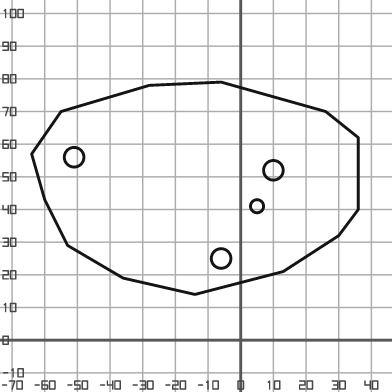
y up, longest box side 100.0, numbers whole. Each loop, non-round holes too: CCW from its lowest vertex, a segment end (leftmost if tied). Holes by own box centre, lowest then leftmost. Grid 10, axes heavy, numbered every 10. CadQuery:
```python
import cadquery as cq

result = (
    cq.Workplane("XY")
    .moveTo(-14.0, 14.0)
    .lineTo(13.0, 21.0)
    .lineTo(30.0, 32.0)
    .lineTo(36.0, 40.0)
    .lineTo(36.0, 62.0)
    .lineTo(26.0, 70.0)
    .lineTo(-6.0, 79.0)
    .lineTo(-28.0, 78.0)
    .lineTo(-55.0, 70.0)
    .lineTo(-64.0, 57.0)
    .lineTo(-60.0, 43.0)
    .lineTo(-53.0, 29.0)
    .lineTo(-36.0, 19.0)
    .close()
    .moveTo(-6.0, 25.0)
    .circle(3.0)
    .moveTo(5.0, 41.0)
    .circle(2.0)
    .moveTo(10.0, 52.0)
    .circle(3.0)
    .moveTo(-51.0, 56.0)
    .circle(3.0)
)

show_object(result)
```